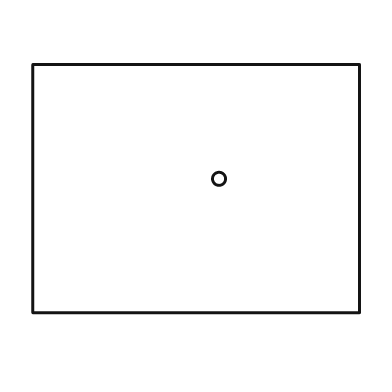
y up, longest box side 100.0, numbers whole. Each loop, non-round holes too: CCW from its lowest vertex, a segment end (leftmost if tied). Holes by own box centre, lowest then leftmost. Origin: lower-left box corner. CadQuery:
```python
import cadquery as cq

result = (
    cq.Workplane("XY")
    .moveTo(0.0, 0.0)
    .lineTo(100.0, 0.0)
    .lineTo(100.0, 76.0)
    .lineTo(0.0, 76.0)
    .close()
    .moveTo(57.0, 41.0)
    .circle(2.0)
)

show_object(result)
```